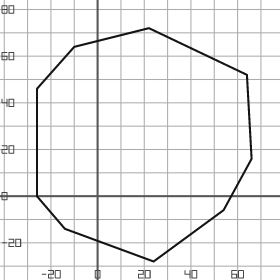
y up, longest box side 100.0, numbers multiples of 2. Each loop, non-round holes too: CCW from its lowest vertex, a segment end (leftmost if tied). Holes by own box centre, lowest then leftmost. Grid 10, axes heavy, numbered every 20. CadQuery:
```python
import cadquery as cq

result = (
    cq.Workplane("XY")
    .moveTo(24.0, -28.0)
    .lineTo(54.0, -6.0)
    .lineTo(66.0, 16.0)
    .lineTo(64.0, 52.0)
    .lineTo(22.0, 72.0)
    .lineTo(-10.0, 64.0)
    .lineTo(-26.0, 46.0)
    .lineTo(-26.0, 0.0)
    .lineTo(-14.0, -14.0)
    .close()
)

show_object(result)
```